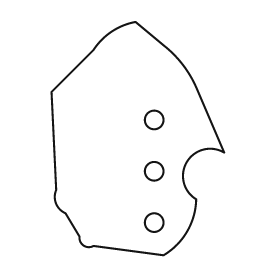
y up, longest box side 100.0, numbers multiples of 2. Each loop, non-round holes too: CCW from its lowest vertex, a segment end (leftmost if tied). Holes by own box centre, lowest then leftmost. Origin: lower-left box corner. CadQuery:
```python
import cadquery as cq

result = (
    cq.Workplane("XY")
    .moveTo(48.0, 0.0)
    .threePointArc((58.0, 10.0), (62.0, 24.0))
    .threePointArc((58.0, 40.0), (74.0, 44.0))
    .lineTo(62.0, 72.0)
    .threePointArc((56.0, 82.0), (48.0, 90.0))
    .lineTo(36.0, 100.0)
    .threePointArc((26.0, 96.0), (18.0, 88.0))
    .lineTo(0.0, 70.0)
    .lineTo(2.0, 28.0)
    .threePointArc((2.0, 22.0), (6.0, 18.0))
    .lineTo(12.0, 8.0)
    .threePointArc((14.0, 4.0), (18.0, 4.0))
    .close()
    .moveTo(44.0, 14.0)
    .circle(4.0)
    .moveTo(44.0, 36.0)
    .circle(4.0)
    .moveTo(44.0, 58.0)
    .circle(4.0)
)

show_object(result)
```